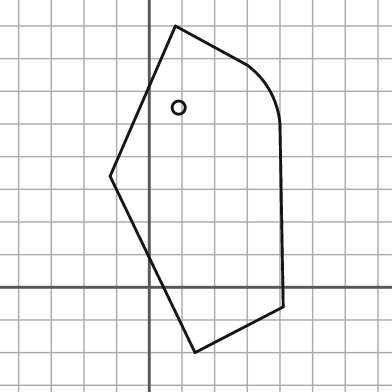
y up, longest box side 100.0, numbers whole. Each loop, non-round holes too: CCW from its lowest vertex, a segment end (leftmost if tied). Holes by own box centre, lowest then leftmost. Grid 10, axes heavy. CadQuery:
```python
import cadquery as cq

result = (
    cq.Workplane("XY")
    .moveTo(14.0, -20.0)
    .lineTo(41.0, -6.0)
    .lineTo(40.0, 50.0)
    .threePointArc((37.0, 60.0), (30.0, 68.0))
    .lineTo(8.0, 80.0)
    .lineTo(-12.0, 34.0)
    .close()
    .moveTo(9.0, 55.0)
    .circle(2.0)
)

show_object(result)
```